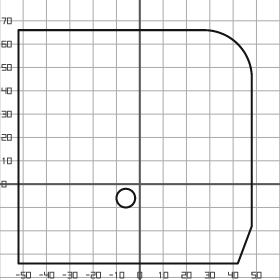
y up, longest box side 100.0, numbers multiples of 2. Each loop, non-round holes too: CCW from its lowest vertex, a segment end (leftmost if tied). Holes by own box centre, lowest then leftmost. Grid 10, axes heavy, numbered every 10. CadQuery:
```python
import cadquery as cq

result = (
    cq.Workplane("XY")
    .moveTo(-52.0, -34.0)
    .lineTo(42.0, -34.0)
    .lineTo(48.0, -18.0)
    .lineTo(48.0, 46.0)
    .threePointArc((42.0, 60.0), (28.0, 66.0))
    .lineTo(-52.0, 66.0)
    .close()
    .moveTo(-6.0, -6.0)
    .circle(4.0)
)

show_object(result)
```